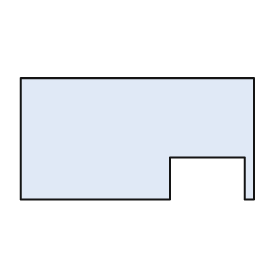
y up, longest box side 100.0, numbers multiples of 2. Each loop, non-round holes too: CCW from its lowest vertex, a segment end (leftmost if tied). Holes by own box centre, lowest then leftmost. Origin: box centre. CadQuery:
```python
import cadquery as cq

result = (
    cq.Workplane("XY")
    .moveTo(-50.0, -26.0)
    .lineTo(14.0, -26.0)
    .lineTo(14.0, -8.0)
    .lineTo(46.0, -8.0)
    .lineTo(46.0, -26.0)
    .lineTo(50.0, -26.0)
    .lineTo(50.0, 26.0)
    .lineTo(-50.0, 26.0)
    .close()
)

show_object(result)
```